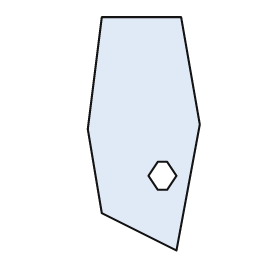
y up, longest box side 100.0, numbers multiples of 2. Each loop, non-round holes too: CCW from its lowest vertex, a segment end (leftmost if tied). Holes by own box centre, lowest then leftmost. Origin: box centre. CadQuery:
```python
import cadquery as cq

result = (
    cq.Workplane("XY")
    .moveTo(14.0, -50.0)
    .lineTo(24.0, 4.0)
    .lineTo(16.0, 50.0)
    .lineTo(-18.0, 50.0)
    .lineTo(-24.0, 2.0)
    .lineTo(-18.0, -34.0)
    .close()
    .moveTo(6.0, -24.0)
    .lineTo(10.0, -24.0)
    .lineTo(14.0, -18.0)
    .lineTo(10.0, -12.0)
    .lineTo(6.0, -12.0)
    .lineTo(2.0, -18.0)
    .close()
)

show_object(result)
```